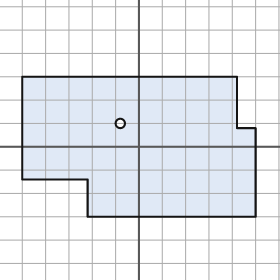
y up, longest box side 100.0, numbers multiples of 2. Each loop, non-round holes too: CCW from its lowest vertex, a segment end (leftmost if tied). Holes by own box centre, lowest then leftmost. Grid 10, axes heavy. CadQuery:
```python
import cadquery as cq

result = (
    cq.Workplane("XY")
    .moveTo(-22.0, -30.0)
    .lineTo(50.0, -30.0)
    .lineTo(50.0, 8.0)
    .lineTo(42.0, 8.0)
    .lineTo(42.0, 30.0)
    .lineTo(-50.0, 30.0)
    .lineTo(-50.0, -14.0)
    .lineTo(-22.0, -14.0)
    .close()
    .moveTo(-8.0, 10.0)
    .circle(2.0)
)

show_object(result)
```